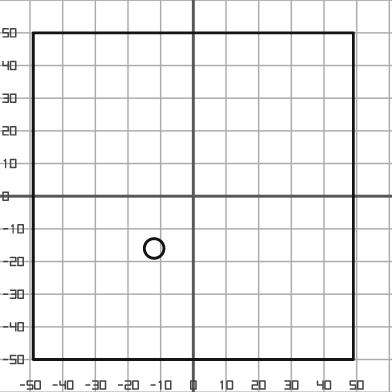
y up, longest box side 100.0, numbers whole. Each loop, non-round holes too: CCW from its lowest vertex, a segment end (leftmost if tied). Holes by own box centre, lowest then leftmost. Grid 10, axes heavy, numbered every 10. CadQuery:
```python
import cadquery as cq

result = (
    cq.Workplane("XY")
    .moveTo(-49.0, -50.0)
    .lineTo(49.0, -50.0)
    .lineTo(49.0, 50.0)
    .lineTo(-49.0, 50.0)
    .close()
    .moveTo(-12.0, -16.0)
    .circle(3.0)
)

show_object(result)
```